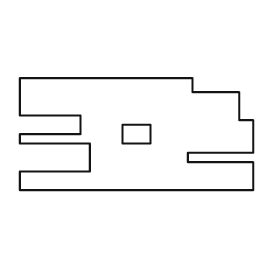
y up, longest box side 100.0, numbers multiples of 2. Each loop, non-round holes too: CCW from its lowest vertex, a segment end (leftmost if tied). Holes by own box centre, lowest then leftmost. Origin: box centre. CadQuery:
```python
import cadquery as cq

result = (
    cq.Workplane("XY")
    .moveTo(-50.0, -24.0)
    .lineTo(50.0, -24.0)
    .lineTo(50.0, -12.0)
    .lineTo(22.0, -12.0)
    .lineTo(22.0, -8.0)
    .lineTo(50.0, -8.0)
    .lineTo(50.0, 6.0)
    .lineTo(44.0, 6.0)
    .lineTo(44.0, 18.0)
    .lineTo(24.0, 18.0)
    .lineTo(24.0, 24.0)
    .lineTo(-50.0, 24.0)
    .lineTo(-50.0, 8.0)
    .lineTo(-24.0, 8.0)
    .lineTo(-24.0, 0.0)
    .lineTo(-50.0, 0.0)
    .lineTo(-50.0, -4.0)
    .lineTo(-20.0, -4.0)
    .lineTo(-20.0, -16.0)
    .lineTo(-50.0, -16.0)
    .close()
    .moveTo(-6.0, -4.0)
    .lineTo(6.0, -4.0)
    .lineTo(6.0, 4.0)
    .lineTo(-6.0, 4.0)
    .close()
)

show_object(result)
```